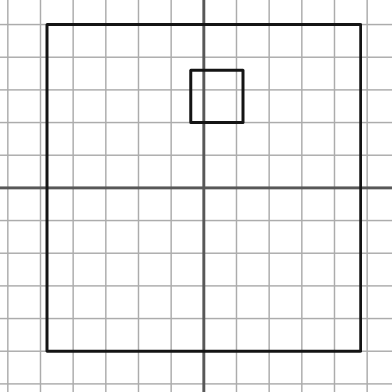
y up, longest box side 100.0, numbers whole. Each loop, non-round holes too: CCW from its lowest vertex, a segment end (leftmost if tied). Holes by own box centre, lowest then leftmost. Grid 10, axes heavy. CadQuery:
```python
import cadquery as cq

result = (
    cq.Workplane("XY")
    .moveTo(-48.0, -50.0)
    .lineTo(48.0, -50.0)
    .lineTo(48.0, 50.0)
    .lineTo(-48.0, 50.0)
    .close()
    .moveTo(-4.0, 20.0)
    .lineTo(12.0, 20.0)
    .lineTo(12.0, 36.0)
    .lineTo(-4.0, 36.0)
    .close()
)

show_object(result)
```